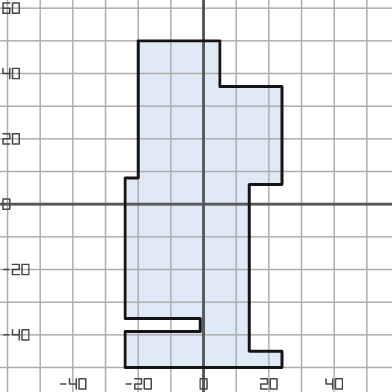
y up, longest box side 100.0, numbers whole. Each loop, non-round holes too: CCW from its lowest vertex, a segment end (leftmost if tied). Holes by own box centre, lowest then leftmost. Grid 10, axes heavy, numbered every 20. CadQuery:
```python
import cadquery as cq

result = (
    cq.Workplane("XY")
    .moveTo(-24.0, -50.0)
    .lineTo(24.0, -50.0)
    .lineTo(24.0, -45.0)
    .lineTo(14.0, -45.0)
    .lineTo(14.0, 6.0)
    .lineTo(24.0, 6.0)
    .lineTo(24.0, 36.0)
    .lineTo(5.0, 36.0)
    .lineTo(5.0, 50.0)
    .lineTo(-20.0, 50.0)
    .lineTo(-20.0, 8.0)
    .lineTo(-24.0, 8.0)
    .lineTo(-24.0, -35.0)
    .lineTo(-1.0, -35.0)
    .lineTo(-1.0, -39.0)
    .lineTo(-24.0, -39.0)
    .close()
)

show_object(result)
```